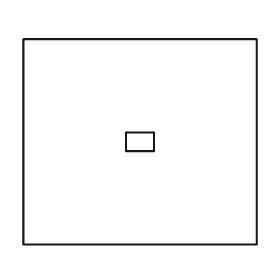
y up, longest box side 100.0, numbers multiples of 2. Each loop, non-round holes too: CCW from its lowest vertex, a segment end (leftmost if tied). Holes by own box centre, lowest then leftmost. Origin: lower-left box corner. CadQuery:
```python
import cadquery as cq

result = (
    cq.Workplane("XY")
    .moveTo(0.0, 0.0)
    .lineTo(100.0, 0.0)
    .lineTo(100.0, 88.0)
    .lineTo(0.0, 88.0)
    .close()
    .moveTo(44.0, 40.0)
    .lineTo(56.0, 40.0)
    .lineTo(56.0, 48.0)
    .lineTo(44.0, 48.0)
    .close()
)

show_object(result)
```